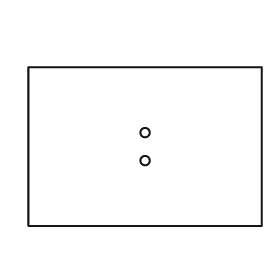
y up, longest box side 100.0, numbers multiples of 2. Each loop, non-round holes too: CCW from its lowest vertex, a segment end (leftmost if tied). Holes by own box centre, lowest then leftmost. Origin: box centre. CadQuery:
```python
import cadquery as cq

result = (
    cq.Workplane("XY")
    .moveTo(-50.0, -34.0)
    .lineTo(50.0, -34.0)
    .lineTo(50.0, 34.0)
    .lineTo(-50.0, 34.0)
    .close()
    .moveTo(0.0, -6.0)
    .circle(2.0)
    .moveTo(0.0, 6.0)
    .circle(2.0)
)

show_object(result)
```